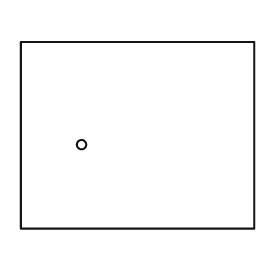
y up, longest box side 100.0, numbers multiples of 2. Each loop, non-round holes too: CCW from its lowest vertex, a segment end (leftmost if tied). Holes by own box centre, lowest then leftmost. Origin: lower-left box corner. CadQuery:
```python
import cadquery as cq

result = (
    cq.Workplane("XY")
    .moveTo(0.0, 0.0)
    .lineTo(100.0, 0.0)
    .lineTo(100.0, 80.0)
    .lineTo(0.0, 80.0)
    .close()
    .moveTo(26.0, 36.0)
    .circle(2.0)
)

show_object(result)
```